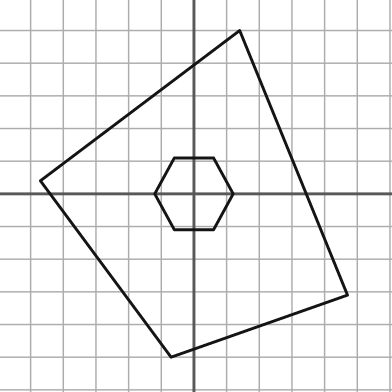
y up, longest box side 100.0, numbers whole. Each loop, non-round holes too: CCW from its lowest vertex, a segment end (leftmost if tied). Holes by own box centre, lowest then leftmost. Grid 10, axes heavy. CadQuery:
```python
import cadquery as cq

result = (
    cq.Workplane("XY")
    .moveTo(-7.0, -50.0)
    .lineTo(47.0, -31.0)
    .lineTo(14.0, 50.0)
    .lineTo(-47.0, 4.0)
    .close()
    .moveTo(-6.0, -11.0)
    .lineTo(6.0, -11.0)
    .lineTo(12.0, 0.0)
    .lineTo(6.0, 11.0)
    .lineTo(-6.0, 11.0)
    .lineTo(-12.0, 0.0)
    .close()
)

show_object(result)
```